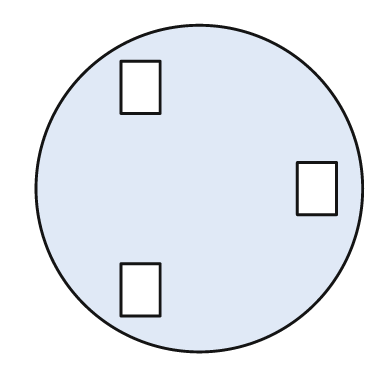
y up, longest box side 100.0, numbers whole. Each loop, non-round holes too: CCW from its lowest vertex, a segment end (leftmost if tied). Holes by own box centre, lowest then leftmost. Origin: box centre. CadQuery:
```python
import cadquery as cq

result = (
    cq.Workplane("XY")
    .moveTo(0.0, 0.0)
    .circle(50.0)
    .moveTo(-24.0, -39.0)
    .lineTo(-12.0, -39.0)
    .lineTo(-12.0, -23.0)
    .lineTo(-24.0, -23.0)
    .close()
    .moveTo(30.0, -8.0)
    .lineTo(42.0, -8.0)
    .lineTo(42.0, 8.0)
    .lineTo(30.0, 8.0)
    .close()
    .moveTo(-24.0, 23.0)
    .lineTo(-12.0, 23.0)
    .lineTo(-12.0, 39.0)
    .lineTo(-24.0, 39.0)
    .close()
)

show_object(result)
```